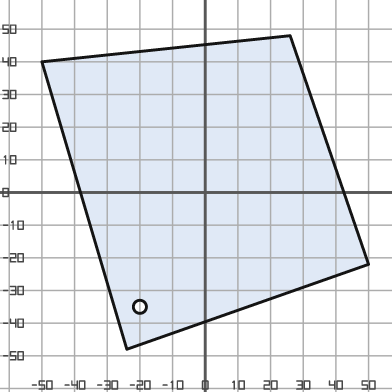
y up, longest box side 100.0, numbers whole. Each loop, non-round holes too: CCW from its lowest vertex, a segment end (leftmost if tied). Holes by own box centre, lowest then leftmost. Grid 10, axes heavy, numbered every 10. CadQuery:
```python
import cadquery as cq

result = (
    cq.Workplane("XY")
    .moveTo(-24.0, -48.0)
    .lineTo(50.0, -22.0)
    .lineTo(26.0, 48.0)
    .lineTo(-50.0, 40.0)
    .close()
    .moveTo(-20.0, -35.0)
    .circle(2.0)
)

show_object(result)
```